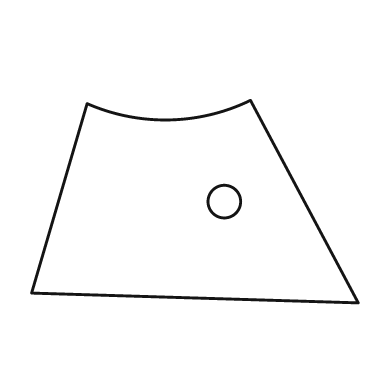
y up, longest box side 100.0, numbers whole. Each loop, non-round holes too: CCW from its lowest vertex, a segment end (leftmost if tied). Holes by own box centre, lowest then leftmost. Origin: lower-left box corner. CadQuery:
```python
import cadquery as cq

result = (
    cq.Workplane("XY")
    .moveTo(100.0, 0.0)
    .lineTo(67.0, 62.0)
    .threePointArc((42.0, 56.0), (17.0, 61.0))
    .lineTo(0.0, 3.0)
    .close()
    .moveTo(59.0, 31.0)
    .circle(5.0)
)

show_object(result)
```